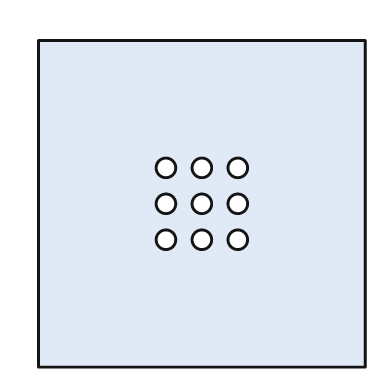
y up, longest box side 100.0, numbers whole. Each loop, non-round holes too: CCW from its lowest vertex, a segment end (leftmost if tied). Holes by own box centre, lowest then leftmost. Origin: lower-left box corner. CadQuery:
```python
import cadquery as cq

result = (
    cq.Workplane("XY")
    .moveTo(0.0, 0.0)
    .lineTo(100.0, 0.0)
    .lineTo(100.0, 100.0)
    .lineTo(0.0, 100.0)
    .close()
    .moveTo(39.0, 39.0)
    .circle(3.0)
    .moveTo(50.0, 39.0)
    .circle(3.0)
    .moveTo(61.0, 39.0)
    .circle(3.0)
    .moveTo(39.0, 50.0)
    .circle(3.0)
    .moveTo(50.0, 50.0)
    .circle(3.0)
    .moveTo(61.0, 50.0)
    .circle(3.0)
    .moveTo(39.0, 61.0)
    .circle(3.0)
    .moveTo(50.0, 61.0)
    .circle(3.0)
    .moveTo(61.0, 61.0)
    .circle(3.0)
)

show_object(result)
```